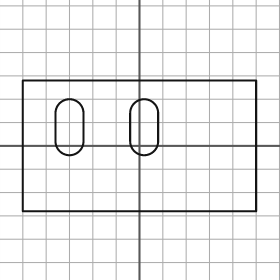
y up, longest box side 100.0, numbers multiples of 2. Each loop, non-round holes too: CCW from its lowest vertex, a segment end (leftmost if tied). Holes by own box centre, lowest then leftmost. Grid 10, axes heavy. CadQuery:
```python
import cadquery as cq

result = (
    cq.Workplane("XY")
    .moveTo(-50.0, -28.0)
    .lineTo(50.0, -28.0)
    .lineTo(50.0, 28.0)
    .lineTo(-50.0, 28.0)
    .close()
    .moveTo(-36.0, 2.0)
    .threePointArc((-30.0, -4.0), (-24.0, 2.0))
    .lineTo(-24.0, 14.0)
    .threePointArc((-30.0, 20.0), (-36.0, 14.0))
    .close()
    .moveTo(-4.0, 2.0)
    .threePointArc((2.0, -4.0), (8.0, 2.0))
    .lineTo(8.0, 14.0)
    .threePointArc((2.0, 20.0), (-4.0, 14.0))
    .close()
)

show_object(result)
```